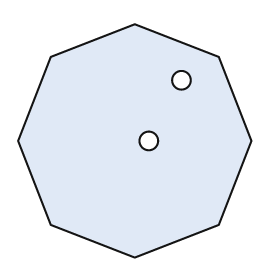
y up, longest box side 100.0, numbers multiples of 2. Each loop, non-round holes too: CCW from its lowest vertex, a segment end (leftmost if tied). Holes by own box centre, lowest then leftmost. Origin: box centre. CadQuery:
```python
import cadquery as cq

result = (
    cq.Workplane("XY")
    .moveTo(0.0, -50.0)
    .lineTo(36.0, -36.0)
    .lineTo(50.0, 0.0)
    .lineTo(36.0, 36.0)
    .lineTo(0.0, 50.0)
    .lineTo(-36.0, 36.0)
    .lineTo(-50.0, 0.0)
    .lineTo(-36.0, -36.0)
    .close()
    .moveTo(6.0, 0.0)
    .circle(4.0)
    .moveTo(20.0, 26.0)
    .circle(4.0)
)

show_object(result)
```